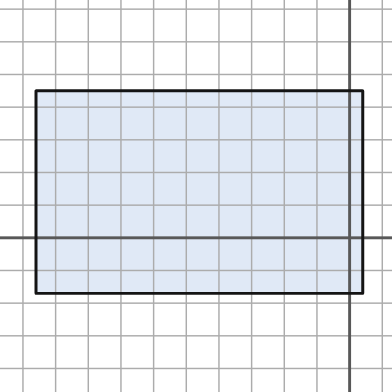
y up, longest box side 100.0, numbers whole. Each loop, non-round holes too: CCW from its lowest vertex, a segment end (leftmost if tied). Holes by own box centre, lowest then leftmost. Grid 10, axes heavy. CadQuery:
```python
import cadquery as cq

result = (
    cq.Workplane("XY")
    .moveTo(-96.0, -17.0)
    .lineTo(4.0, -17.0)
    .lineTo(4.0, 45.0)
    .lineTo(-96.0, 45.0)
    .close()
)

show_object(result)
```